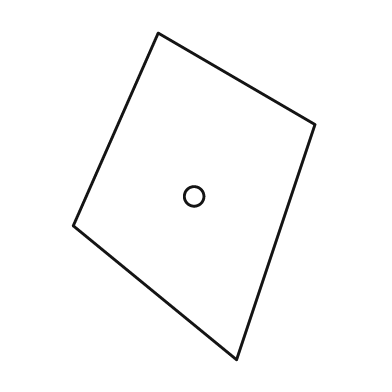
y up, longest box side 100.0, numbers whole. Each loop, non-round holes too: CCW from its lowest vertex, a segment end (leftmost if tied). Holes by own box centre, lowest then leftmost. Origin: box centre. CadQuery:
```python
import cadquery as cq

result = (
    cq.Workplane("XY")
    .moveTo(13.0, -50.0)
    .lineTo(37.0, 22.0)
    .lineTo(-11.0, 50.0)
    .lineTo(-37.0, -9.0)
    .close()
    .moveTo(0.0, 0.0)
    .circle(3.0)
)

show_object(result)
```